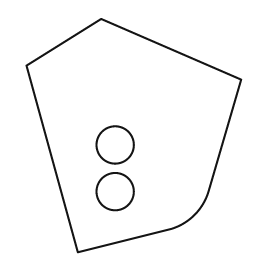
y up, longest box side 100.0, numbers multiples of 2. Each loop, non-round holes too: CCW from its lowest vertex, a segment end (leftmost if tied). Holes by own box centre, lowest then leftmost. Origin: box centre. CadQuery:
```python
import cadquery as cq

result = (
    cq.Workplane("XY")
    .moveTo(-24.0, -50.0)
    .lineTo(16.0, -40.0)
    .threePointArc((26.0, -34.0), (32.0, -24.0))
    .lineTo(46.0, 24.0)
    .lineTo(-14.0, 50.0)
    .lineTo(-46.0, 30.0)
    .close()
    .moveTo(-8.0, -24.0)
    .circle(8.0)
    .moveTo(-8.0, -4.0)
    .circle(8.0)
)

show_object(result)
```